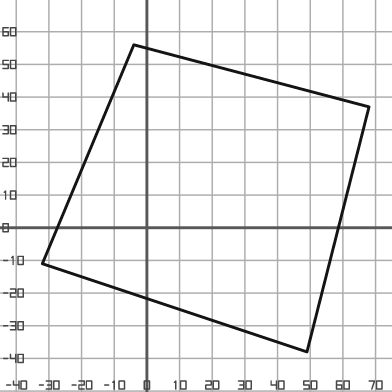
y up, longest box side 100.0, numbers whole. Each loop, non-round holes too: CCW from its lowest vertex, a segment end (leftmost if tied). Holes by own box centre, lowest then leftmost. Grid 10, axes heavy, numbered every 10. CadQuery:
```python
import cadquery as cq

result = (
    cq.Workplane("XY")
    .moveTo(49.0, -38.0)
    .lineTo(68.0, 37.0)
    .lineTo(-4.0, 56.0)
    .lineTo(-32.0, -11.0)
    .close()
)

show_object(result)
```